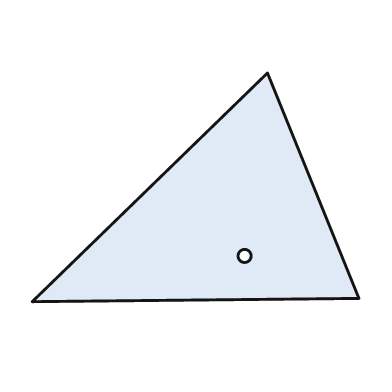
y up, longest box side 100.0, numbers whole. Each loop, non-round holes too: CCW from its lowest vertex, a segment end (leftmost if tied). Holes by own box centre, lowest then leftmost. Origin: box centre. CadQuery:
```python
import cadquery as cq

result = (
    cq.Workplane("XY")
    .moveTo(-50.0, -35.0)
    .lineTo(50.0, -34.0)
    .lineTo(22.0, 35.0)
    .close()
    .moveTo(15.0, -21.0)
    .circle(2.0)
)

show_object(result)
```